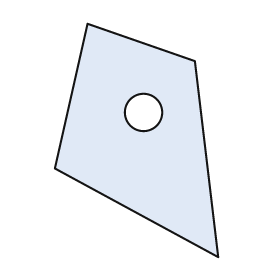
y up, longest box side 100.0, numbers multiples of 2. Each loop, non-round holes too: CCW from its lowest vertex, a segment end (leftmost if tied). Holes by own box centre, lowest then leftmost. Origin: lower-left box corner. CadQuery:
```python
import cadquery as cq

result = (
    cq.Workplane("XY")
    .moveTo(70.0, 0.0)
    .lineTo(60.0, 84.0)
    .lineTo(14.0, 100.0)
    .lineTo(0.0, 38.0)
    .close()
    .moveTo(38.0, 62.0)
    .circle(8.0)
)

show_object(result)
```